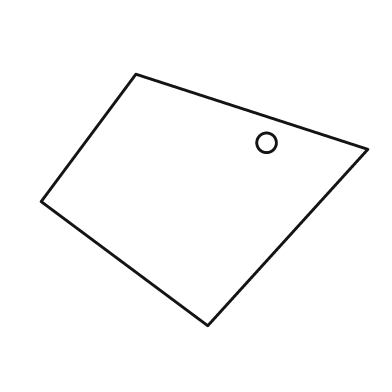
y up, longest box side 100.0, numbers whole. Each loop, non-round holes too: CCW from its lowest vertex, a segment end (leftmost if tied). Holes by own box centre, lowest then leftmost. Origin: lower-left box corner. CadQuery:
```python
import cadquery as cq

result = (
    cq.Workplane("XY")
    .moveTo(51.0, 0.0)
    .lineTo(100.0, 54.0)
    .lineTo(29.0, 77.0)
    .lineTo(0.0, 38.0)
    .close()
    .moveTo(69.0, 56.0)
    .circle(3.0)
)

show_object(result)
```